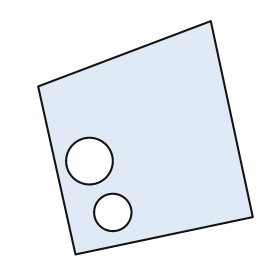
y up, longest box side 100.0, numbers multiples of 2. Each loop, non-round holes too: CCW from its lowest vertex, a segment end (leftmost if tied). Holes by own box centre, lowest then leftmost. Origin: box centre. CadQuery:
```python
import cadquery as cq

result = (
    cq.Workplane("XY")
    .moveTo(-30.0, -50.0)
    .lineTo(46.0, -34.0)
    .lineTo(28.0, 50.0)
    .lineTo(-46.0, 22.0)
    .close()
    .moveTo(-14.0, -32.0)
    .circle(8.0)
    .moveTo(-24.0, -10.0)
    .circle(10.0)
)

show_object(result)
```